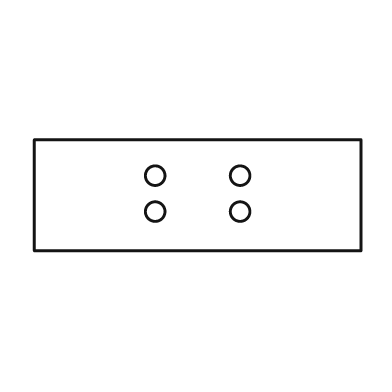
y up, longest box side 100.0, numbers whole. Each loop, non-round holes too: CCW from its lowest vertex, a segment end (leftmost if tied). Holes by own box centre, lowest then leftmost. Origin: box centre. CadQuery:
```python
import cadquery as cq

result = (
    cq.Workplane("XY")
    .moveTo(-50.0, -17.0)
    .lineTo(50.0, -17.0)
    .lineTo(50.0, 17.0)
    .lineTo(-50.0, 17.0)
    .close()
    .moveTo(-13.0, -5.0)
    .circle(3.0)
    .moveTo(13.0, -5.0)
    .circle(3.0)
    .moveTo(-13.0, 6.0)
    .circle(3.0)
    .moveTo(13.0, 6.0)
    .circle(3.0)
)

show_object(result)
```